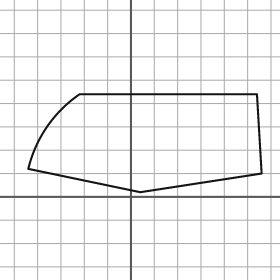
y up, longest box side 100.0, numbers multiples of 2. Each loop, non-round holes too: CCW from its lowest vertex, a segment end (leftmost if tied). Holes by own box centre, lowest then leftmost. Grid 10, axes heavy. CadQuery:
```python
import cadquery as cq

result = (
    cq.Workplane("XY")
    .moveTo(4.0, 2.0)
    .lineTo(56.0, 10.0)
    .lineTo(54.0, 44.0)
    .lineTo(-22.0, 44.0)
    .threePointArc((-36.0, 30.0), (-44.0, 12.0))
    .close()
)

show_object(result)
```